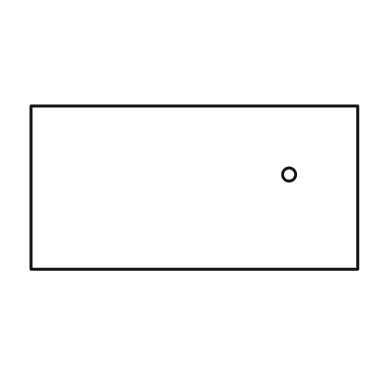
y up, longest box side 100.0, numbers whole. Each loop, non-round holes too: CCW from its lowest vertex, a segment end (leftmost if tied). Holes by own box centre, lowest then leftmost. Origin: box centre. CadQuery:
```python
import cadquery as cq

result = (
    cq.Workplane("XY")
    .moveTo(-50.0, -25.0)
    .lineTo(50.0, -25.0)
    .lineTo(50.0, 25.0)
    .lineTo(-50.0, 25.0)
    .close()
    .moveTo(29.0, 4.0)
    .circle(2.0)
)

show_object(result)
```